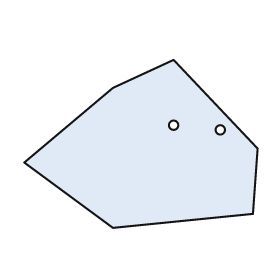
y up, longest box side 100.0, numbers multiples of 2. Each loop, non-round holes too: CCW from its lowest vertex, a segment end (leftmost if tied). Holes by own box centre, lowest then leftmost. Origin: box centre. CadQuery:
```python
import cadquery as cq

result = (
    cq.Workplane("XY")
    .moveTo(-12.0, -36.0)
    .lineTo(48.0, -30.0)
    .lineTo(50.0, -2.0)
    .lineTo(14.0, 36.0)
    .lineTo(-12.0, 24.0)
    .lineTo(-50.0, -8.0)
    .close()
    .moveTo(34.0, 6.0)
    .circle(2.0)
    .moveTo(14.0, 8.0)
    .circle(2.0)
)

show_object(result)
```